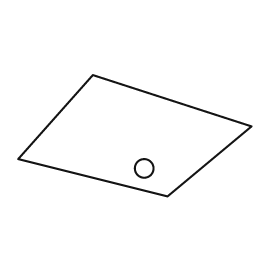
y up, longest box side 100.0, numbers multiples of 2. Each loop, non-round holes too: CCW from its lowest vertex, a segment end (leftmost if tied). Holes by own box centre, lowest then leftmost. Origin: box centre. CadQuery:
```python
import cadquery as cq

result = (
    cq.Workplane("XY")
    .moveTo(14.0, -26.0)
    .lineTo(50.0, 4.0)
    .lineTo(-18.0, 26.0)
    .lineTo(-50.0, -10.0)
    .close()
    .moveTo(4.0, -14.0)
    .circle(4.0)
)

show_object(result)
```